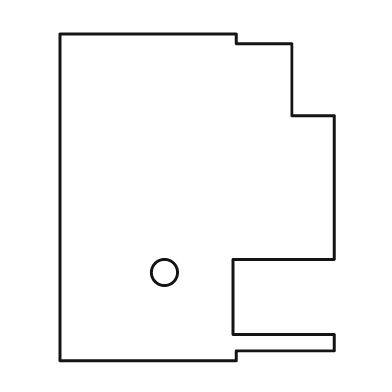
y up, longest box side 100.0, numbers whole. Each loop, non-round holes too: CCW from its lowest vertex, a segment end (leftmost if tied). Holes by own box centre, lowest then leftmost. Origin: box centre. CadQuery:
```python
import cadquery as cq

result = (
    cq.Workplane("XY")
    .moveTo(-42.0, -50.0)
    .lineTo(12.0, -50.0)
    .lineTo(12.0, -47.0)
    .lineTo(42.0, -47.0)
    .lineTo(42.0, -42.0)
    .lineTo(11.0, -42.0)
    .lineTo(11.0, -19.0)
    .lineTo(42.0, -19.0)
    .lineTo(42.0, 25.0)
    .lineTo(29.0, 25.0)
    .lineTo(29.0, 47.0)
    .lineTo(12.0, 47.0)
    .lineTo(12.0, 50.0)
    .lineTo(-42.0, 50.0)
    .close()
    .moveTo(-10.0, -23.0)
    .circle(4.0)
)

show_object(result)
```